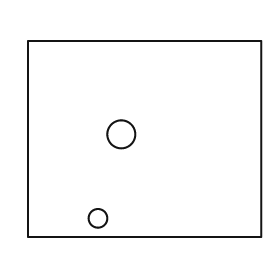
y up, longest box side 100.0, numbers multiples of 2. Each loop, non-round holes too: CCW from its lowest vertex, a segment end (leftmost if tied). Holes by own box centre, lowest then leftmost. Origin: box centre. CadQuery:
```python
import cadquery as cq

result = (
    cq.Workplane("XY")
    .moveTo(-50.0, -42.0)
    .lineTo(50.0, -42.0)
    .lineTo(50.0, 42.0)
    .lineTo(-50.0, 42.0)
    .close()
    .moveTo(-20.0, -34.0)
    .circle(4.0)
    .moveTo(-10.0, 2.0)
    .circle(6.0)
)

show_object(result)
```